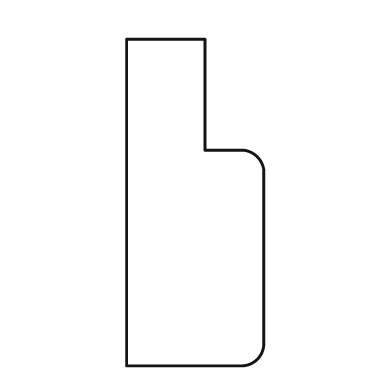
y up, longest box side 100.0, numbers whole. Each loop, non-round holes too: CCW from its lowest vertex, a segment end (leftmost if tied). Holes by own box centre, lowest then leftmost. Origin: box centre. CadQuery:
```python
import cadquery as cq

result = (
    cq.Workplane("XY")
    .moveTo(-21.0, -50.0)
    .lineTo(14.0, -50.0)
    .threePointArc((19.0, -48.0), (21.0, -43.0))
    .lineTo(21.0, 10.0)
    .threePointArc((19.0, 14.0), (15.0, 16.0))
    .lineTo(3.0, 16.0)
    .lineTo(3.0, 50.0)
    .lineTo(-21.0, 50.0)
    .close()
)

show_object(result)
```